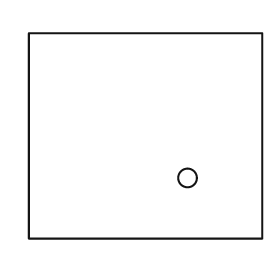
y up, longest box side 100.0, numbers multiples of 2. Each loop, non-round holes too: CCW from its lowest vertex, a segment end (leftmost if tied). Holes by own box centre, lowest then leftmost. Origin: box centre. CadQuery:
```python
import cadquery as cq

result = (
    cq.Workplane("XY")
    .moveTo(-50.0, -44.0)
    .lineTo(50.0, -44.0)
    .lineTo(50.0, 44.0)
    .lineTo(-50.0, 44.0)
    .close()
    .moveTo(18.0, -18.0)
    .circle(4.0)
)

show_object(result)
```